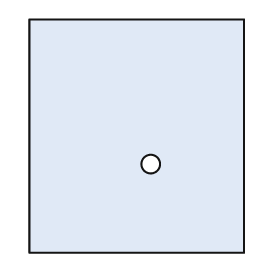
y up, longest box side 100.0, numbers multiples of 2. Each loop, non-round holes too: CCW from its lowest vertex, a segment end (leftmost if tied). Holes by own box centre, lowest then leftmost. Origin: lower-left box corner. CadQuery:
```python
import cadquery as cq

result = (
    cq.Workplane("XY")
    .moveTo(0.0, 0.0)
    .lineTo(92.0, 0.0)
    .lineTo(92.0, 100.0)
    .lineTo(0.0, 100.0)
    .close()
    .moveTo(52.0, 38.0)
    .circle(4.0)
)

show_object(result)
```